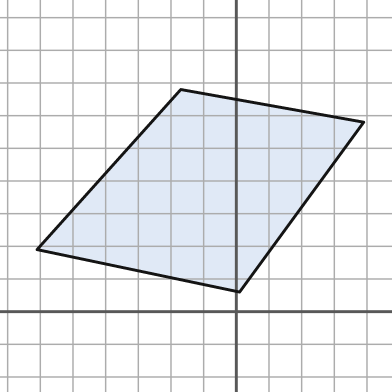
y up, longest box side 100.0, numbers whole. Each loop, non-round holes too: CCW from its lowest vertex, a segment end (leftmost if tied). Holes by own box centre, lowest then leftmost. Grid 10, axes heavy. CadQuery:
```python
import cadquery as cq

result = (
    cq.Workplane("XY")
    .moveTo(1.0, 6.0)
    .lineTo(39.0, 58.0)
    .lineTo(-17.0, 68.0)
    .lineTo(-61.0, 19.0)
    .close()
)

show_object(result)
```